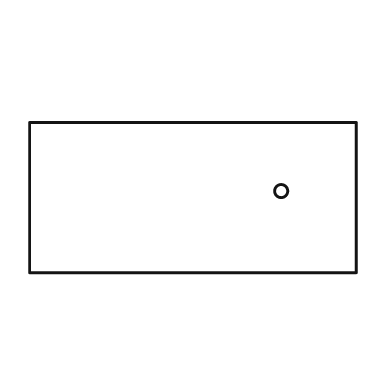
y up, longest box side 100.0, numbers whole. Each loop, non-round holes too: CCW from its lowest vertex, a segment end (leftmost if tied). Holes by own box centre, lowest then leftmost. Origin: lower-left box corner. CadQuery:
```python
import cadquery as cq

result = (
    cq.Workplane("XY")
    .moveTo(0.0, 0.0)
    .lineTo(100.0, 0.0)
    .lineTo(100.0, 46.0)
    .lineTo(0.0, 46.0)
    .close()
    .moveTo(77.0, 25.0)
    .circle(2.0)
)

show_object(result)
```